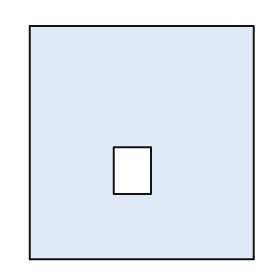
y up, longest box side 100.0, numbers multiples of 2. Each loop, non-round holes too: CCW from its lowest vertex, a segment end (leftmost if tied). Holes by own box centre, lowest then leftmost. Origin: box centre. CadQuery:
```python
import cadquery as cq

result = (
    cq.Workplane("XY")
    .moveTo(-48.0, -50.0)
    .lineTo(48.0, -50.0)
    .lineTo(48.0, 50.0)
    .lineTo(-48.0, 50.0)
    .close()
    .moveTo(-12.0, -22.0)
    .lineTo(4.0, -22.0)
    .lineTo(4.0, -2.0)
    .lineTo(-12.0, -2.0)
    .close()
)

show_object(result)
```